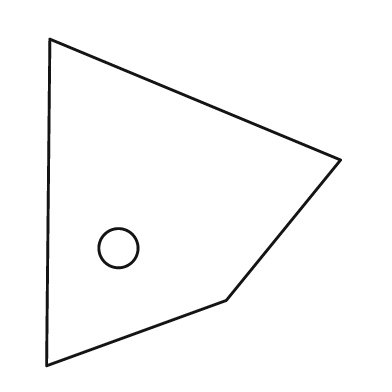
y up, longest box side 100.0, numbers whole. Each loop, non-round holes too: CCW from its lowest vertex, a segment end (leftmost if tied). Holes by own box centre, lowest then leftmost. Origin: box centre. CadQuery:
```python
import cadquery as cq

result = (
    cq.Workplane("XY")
    .moveTo(-45.0, -50.0)
    .lineTo(10.0, -30.0)
    .lineTo(45.0, 13.0)
    .lineTo(-44.0, 50.0)
    .close()
    .moveTo(-23.0, -14.0)
    .circle(6.0)
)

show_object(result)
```